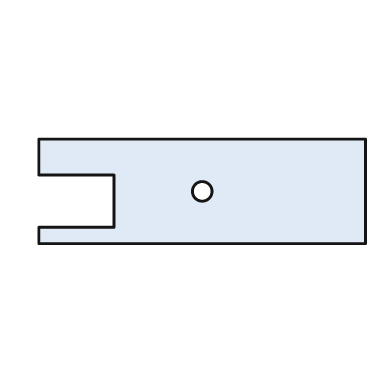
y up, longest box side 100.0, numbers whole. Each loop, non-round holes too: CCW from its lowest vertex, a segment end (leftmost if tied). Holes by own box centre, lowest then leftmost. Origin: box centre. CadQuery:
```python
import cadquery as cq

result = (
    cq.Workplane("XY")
    .moveTo(-50.0, -16.0)
    .lineTo(50.0, -16.0)
    .lineTo(50.0, 16.0)
    .lineTo(-50.0, 16.0)
    .lineTo(-50.0, 5.0)
    .lineTo(-27.0, 5.0)
    .lineTo(-27.0, -11.0)
    .lineTo(-50.0, -11.0)
    .close()
    .moveTo(0.0, 0.0)
    .circle(3.0)
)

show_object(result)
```